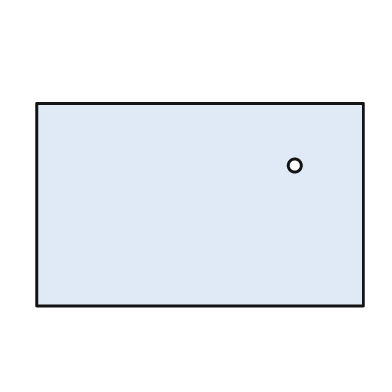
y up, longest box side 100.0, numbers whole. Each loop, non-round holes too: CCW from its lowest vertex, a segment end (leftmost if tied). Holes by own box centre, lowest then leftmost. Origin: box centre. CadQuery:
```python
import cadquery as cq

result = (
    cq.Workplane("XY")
    .moveTo(-50.0, -31.0)
    .lineTo(50.0, -31.0)
    .lineTo(50.0, 31.0)
    .lineTo(-50.0, 31.0)
    .close()
    .moveTo(29.0, 12.0)
    .circle(2.0)
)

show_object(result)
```